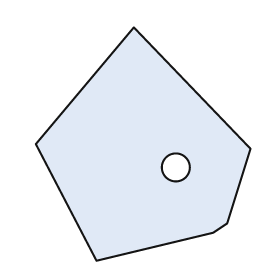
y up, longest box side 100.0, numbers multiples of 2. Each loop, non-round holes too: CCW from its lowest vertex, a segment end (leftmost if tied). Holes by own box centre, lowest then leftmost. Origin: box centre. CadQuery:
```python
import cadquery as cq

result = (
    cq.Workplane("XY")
    .moveTo(-20.0, -50.0)
    .lineTo(30.0, -38.0)
    .lineTo(36.0, -34.0)
    .lineTo(46.0, -2.0)
    .lineTo(-4.0, 50.0)
    .lineTo(-46.0, 0.0)
    .close()
    .moveTo(14.0, -10.0)
    .circle(6.0)
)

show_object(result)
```